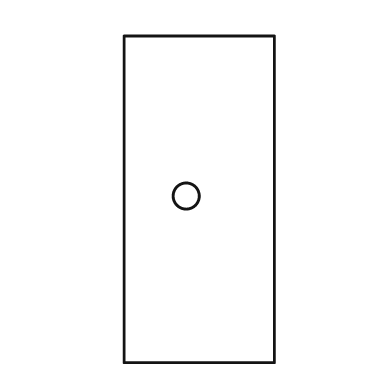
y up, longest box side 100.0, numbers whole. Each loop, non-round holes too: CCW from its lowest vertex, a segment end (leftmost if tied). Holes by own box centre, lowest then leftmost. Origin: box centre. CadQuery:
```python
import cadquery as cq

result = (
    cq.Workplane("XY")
    .moveTo(-23.0, -50.0)
    .lineTo(23.0, -50.0)
    .lineTo(23.0, 50.0)
    .lineTo(-23.0, 50.0)
    .close()
    .moveTo(-4.0, 1.0)
    .circle(4.0)
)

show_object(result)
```